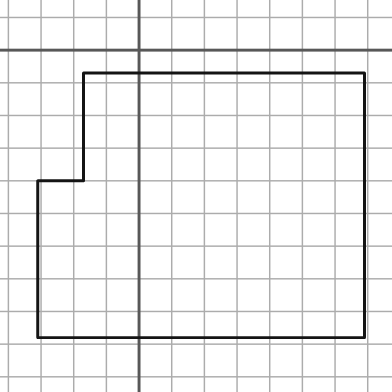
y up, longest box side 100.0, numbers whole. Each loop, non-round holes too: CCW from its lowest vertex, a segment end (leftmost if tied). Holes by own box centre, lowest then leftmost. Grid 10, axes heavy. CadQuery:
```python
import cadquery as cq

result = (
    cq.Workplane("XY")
    .moveTo(-31.0, -88.0)
    .lineTo(69.0, -88.0)
    .lineTo(69.0, -7.0)
    .lineTo(-17.0, -7.0)
    .lineTo(-17.0, -40.0)
    .lineTo(-31.0, -40.0)
    .close()
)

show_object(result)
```